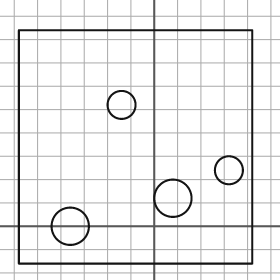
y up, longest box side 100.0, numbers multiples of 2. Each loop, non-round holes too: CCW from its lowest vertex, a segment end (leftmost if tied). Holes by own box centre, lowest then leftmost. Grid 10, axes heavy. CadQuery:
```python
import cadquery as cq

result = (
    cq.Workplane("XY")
    .moveTo(-58.0, -16.0)
    .lineTo(42.0, -16.0)
    .lineTo(42.0, 84.0)
    .lineTo(-58.0, 84.0)
    .close()
    .moveTo(-36.0, 0.0)
    .circle(8.0)
    .moveTo(8.0, 12.0)
    .circle(8.0)
    .moveTo(32.0, 24.0)
    .circle(6.0)
    .moveTo(-14.0, 52.0)
    .circle(6.0)
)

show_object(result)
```